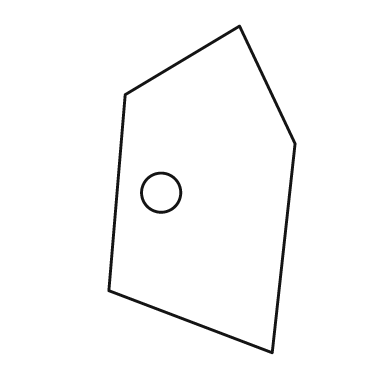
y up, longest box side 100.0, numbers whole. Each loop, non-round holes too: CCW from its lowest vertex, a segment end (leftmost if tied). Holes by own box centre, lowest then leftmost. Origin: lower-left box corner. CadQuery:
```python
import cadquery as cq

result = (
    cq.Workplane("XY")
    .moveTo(50.0, 0.0)
    .lineTo(57.0, 64.0)
    .lineTo(40.0, 100.0)
    .lineTo(5.0, 79.0)
    .lineTo(0.0, 19.0)
    .close()
    .moveTo(16.0, 49.0)
    .circle(6.0)
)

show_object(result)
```